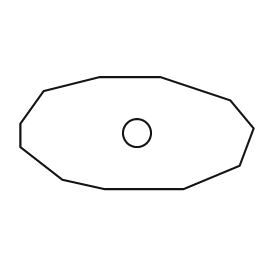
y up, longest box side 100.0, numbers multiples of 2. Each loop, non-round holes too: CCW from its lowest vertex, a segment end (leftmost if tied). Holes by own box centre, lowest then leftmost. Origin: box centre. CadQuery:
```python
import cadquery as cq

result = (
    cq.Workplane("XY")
    .moveTo(-14.0, -24.0)
    .lineTo(20.0, -24.0)
    .lineTo(44.0, -14.0)
    .lineTo(50.0, 2.0)
    .lineTo(40.0, 14.0)
    .lineTo(10.0, 24.0)
    .lineTo(-16.0, 24.0)
    .lineTo(-40.0, 18.0)
    .lineTo(-50.0, 4.0)
    .lineTo(-50.0, -6.0)
    .lineTo(-32.0, -20.0)
    .close()
    .moveTo(0.0, 0.0)
    .circle(6.0)
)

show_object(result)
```